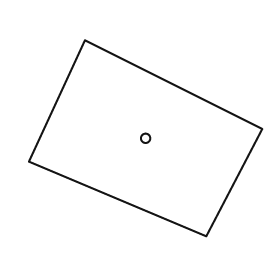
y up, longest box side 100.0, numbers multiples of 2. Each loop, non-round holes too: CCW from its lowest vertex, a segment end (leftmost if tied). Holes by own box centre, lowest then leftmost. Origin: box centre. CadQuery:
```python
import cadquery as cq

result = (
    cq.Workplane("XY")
    .moveTo(26.0, -42.0)
    .lineTo(50.0, 4.0)
    .lineTo(-26.0, 42.0)
    .lineTo(-50.0, -10.0)
    .close()
    .moveTo(0.0, 0.0)
    .circle(2.0)
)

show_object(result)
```